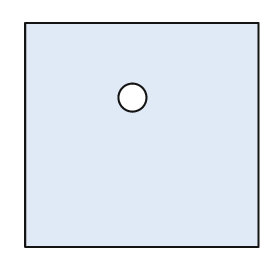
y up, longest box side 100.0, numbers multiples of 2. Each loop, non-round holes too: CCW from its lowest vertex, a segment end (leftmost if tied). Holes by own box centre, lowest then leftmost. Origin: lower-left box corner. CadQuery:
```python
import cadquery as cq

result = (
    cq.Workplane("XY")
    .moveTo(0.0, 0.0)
    .lineTo(100.0, 0.0)
    .lineTo(100.0, 96.0)
    .lineTo(0.0, 96.0)
    .close()
    .moveTo(46.0, 64.0)
    .circle(6.0)
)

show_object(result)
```